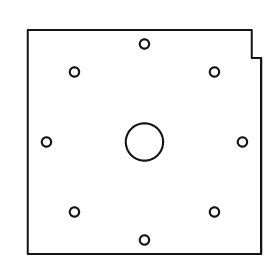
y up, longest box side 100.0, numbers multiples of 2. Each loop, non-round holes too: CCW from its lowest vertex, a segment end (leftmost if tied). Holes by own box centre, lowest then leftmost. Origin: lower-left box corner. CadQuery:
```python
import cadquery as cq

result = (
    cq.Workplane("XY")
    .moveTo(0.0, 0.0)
    .lineTo(100.0, 0.0)
    .lineTo(100.0, 84.0)
    .lineTo(96.0, 84.0)
    .lineTo(96.0, 96.0)
    .lineTo(0.0, 96.0)
    .close()
    .moveTo(50.0, 6.0)
    .circle(2.0)
    .moveTo(20.0, 18.0)
    .circle(2.0)
    .moveTo(80.0, 18.0)
    .circle(2.0)
    .moveTo(8.0, 48.0)
    .circle(2.0)
    .moveTo(50.0, 48.0)
    .circle(8.0)
    .moveTo(92.0, 48.0)
    .circle(2.0)
    .moveTo(20.0, 78.0)
    .circle(2.0)
    .moveTo(80.0, 78.0)
    .circle(2.0)
    .moveTo(50.0, 90.0)
    .circle(2.0)
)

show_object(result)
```